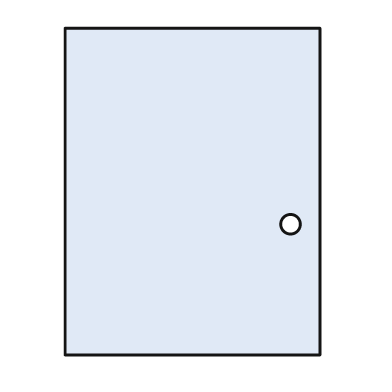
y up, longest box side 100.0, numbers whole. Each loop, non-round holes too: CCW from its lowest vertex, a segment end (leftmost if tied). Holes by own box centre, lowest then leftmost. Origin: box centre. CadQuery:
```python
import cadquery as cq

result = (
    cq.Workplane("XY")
    .moveTo(-39.0, -50.0)
    .lineTo(39.0, -50.0)
    .lineTo(39.0, 50.0)
    .lineTo(-39.0, 50.0)
    .close()
    .moveTo(30.0, -10.0)
    .circle(3.0)
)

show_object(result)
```